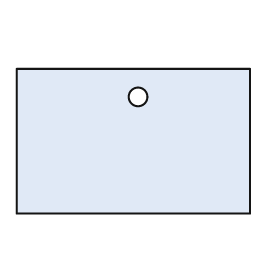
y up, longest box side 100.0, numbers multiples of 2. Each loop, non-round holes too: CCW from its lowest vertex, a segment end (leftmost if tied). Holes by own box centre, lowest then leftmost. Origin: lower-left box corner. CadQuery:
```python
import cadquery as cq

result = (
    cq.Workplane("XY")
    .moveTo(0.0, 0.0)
    .lineTo(100.0, 0.0)
    .lineTo(100.0, 62.0)
    .lineTo(0.0, 62.0)
    .close()
    .moveTo(52.0, 50.0)
    .circle(4.0)
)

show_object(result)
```